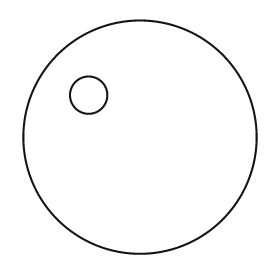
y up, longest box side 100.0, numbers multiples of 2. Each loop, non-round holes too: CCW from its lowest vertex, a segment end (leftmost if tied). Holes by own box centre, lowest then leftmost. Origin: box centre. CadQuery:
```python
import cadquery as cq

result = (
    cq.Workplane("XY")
    .moveTo(0.0, 0.0)
    .circle(50.0)
    .moveTo(-22.0, 18.0)
    .circle(8.0)
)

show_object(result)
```